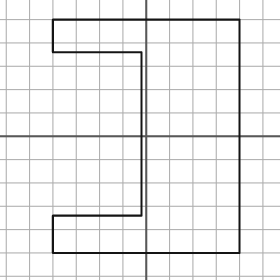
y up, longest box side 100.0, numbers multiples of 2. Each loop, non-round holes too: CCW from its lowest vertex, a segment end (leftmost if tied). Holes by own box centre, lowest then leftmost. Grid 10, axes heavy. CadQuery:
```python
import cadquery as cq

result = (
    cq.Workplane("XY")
    .moveTo(-40.0, -50.0)
    .lineTo(40.0, -50.0)
    .lineTo(40.0, 50.0)
    .lineTo(-40.0, 50.0)
    .lineTo(-40.0, 36.0)
    .lineTo(-2.0, 36.0)
    .lineTo(-2.0, -34.0)
    .lineTo(-40.0, -34.0)
    .close()
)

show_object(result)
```